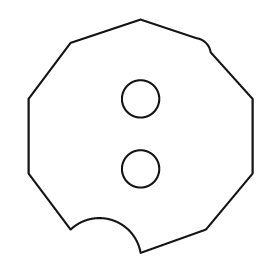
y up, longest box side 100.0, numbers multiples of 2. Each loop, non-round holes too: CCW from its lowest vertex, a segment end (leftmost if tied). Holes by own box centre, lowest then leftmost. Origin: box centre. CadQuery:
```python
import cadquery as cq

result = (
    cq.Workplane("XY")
    .moveTo(0.0, -50.0)
    .lineTo(28.0, -40.0)
    .lineTo(48.0, -16.0)
    .lineTo(48.0, 16.0)
    .lineTo(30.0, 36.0)
    .threePointArc((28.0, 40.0), (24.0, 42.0))
    .lineTo(0.0, 50.0)
    .lineTo(-30.0, 40.0)
    .lineTo(-48.0, 16.0)
    .lineTo(-48.0, -16.0)
    .lineTo(-30.0, -40.0)
    .threePointArc((-12.0, -36.0), (0.0, -50.0))
    .close()
    .moveTo(0.0, -14.0)
    .circle(8.0)
    .moveTo(0.0, 16.0)
    .circle(8.0)
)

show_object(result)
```